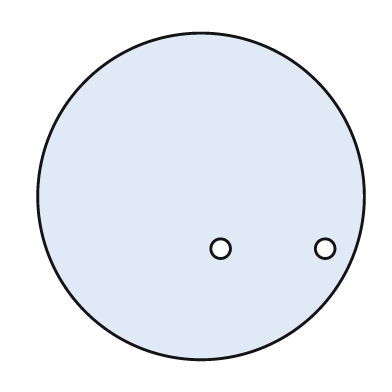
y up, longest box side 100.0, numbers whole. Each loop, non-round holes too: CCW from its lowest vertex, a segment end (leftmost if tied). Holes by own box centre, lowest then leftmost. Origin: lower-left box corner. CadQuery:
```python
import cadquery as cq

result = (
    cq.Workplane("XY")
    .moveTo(50.0, 50.0)
    .circle(50.0)
    .moveTo(56.0, 34.0)
    .circle(3.0)
    .moveTo(88.0, 34.0)
    .circle(3.0)
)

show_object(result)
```